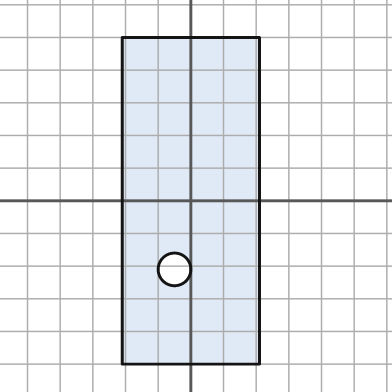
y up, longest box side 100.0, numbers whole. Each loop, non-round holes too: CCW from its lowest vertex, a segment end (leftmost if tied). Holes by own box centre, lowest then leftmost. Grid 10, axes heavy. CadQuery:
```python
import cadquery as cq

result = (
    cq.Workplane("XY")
    .moveTo(-21.0, -50.0)
    .lineTo(21.0, -50.0)
    .lineTo(21.0, 50.0)
    .lineTo(-21.0, 50.0)
    .close()
    .moveTo(-5.0, -21.0)
    .circle(5.0)
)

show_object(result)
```